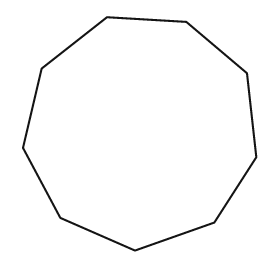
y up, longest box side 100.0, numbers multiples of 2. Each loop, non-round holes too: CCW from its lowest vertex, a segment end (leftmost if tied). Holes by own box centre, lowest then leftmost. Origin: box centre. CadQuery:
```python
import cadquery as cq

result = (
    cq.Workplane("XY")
    .moveTo(-2.0, -50.0)
    .lineTo(32.0, -38.0)
    .lineTo(50.0, -10.0)
    .lineTo(46.0, 26.0)
    .lineTo(20.0, 48.0)
    .lineTo(-14.0, 50.0)
    .lineTo(-42.0, 28.0)
    .lineTo(-50.0, -6.0)
    .lineTo(-34.0, -36.0)
    .close()
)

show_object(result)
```